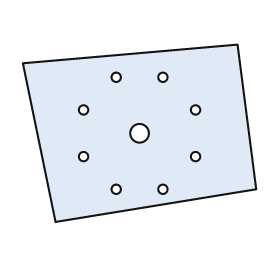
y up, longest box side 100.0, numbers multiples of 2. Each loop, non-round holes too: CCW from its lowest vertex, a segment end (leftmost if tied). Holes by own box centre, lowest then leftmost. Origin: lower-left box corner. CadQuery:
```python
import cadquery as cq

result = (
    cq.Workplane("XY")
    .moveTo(14.0, 0.0)
    .lineTo(100.0, 14.0)
    .lineTo(92.0, 76.0)
    .lineTo(0.0, 68.0)
    .close()
    .moveTo(40.0, 14.0)
    .circle(2.0)
    .moveTo(60.0, 14.0)
    .circle(2.0)
    .moveTo(26.0, 28.0)
    .circle(2.0)
    .moveTo(74.0, 28.0)
    .circle(2.0)
    .moveTo(50.0, 38.0)
    .circle(4.0)
    .moveTo(26.0, 48.0)
    .circle(2.0)
    .moveTo(74.0, 48.0)
    .circle(2.0)
    .moveTo(40.0, 62.0)
    .circle(2.0)
    .moveTo(60.0, 62.0)
    .circle(2.0)
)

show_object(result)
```